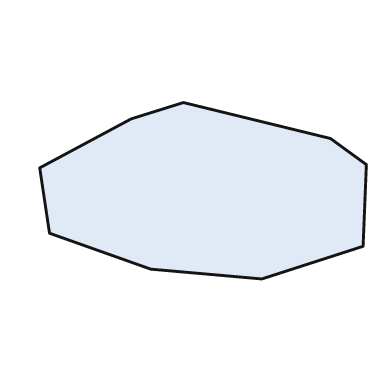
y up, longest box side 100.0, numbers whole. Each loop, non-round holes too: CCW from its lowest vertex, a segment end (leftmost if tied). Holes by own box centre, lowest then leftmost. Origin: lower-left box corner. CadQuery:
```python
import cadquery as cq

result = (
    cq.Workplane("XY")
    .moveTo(68.0, 0.0)
    .lineTo(99.0, 10.0)
    .lineTo(100.0, 35.0)
    .lineTo(89.0, 43.0)
    .lineTo(44.0, 54.0)
    .lineTo(28.0, 49.0)
    .lineTo(0.0, 34.0)
    .lineTo(3.0, 14.0)
    .lineTo(34.0, 3.0)
    .close()
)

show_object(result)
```